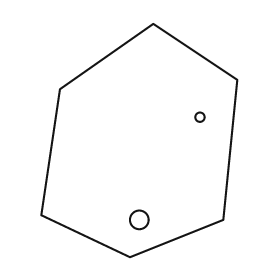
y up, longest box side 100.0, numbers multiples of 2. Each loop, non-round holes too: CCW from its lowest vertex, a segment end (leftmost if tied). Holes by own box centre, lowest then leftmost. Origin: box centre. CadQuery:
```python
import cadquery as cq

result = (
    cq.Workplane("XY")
    .moveTo(-4.0, -50.0)
    .lineTo(36.0, -34.0)
    .lineTo(42.0, 26.0)
    .lineTo(6.0, 50.0)
    .lineTo(-34.0, 22.0)
    .lineTo(-42.0, -32.0)
    .close()
    .moveTo(0.0, -34.0)
    .circle(4.0)
    .moveTo(26.0, 10.0)
    .circle(2.0)
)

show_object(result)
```